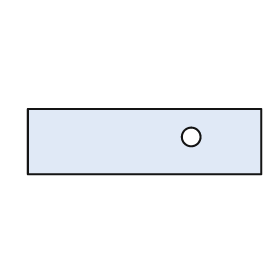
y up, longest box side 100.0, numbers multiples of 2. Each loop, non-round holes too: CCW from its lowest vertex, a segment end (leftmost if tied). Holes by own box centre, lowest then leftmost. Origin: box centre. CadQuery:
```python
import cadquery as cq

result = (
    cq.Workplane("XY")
    .moveTo(-50.0, -14.0)
    .lineTo(50.0, -14.0)
    .lineTo(50.0, 14.0)
    .lineTo(-50.0, 14.0)
    .close()
    .moveTo(20.0, 2.0)
    .circle(4.0)
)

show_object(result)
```